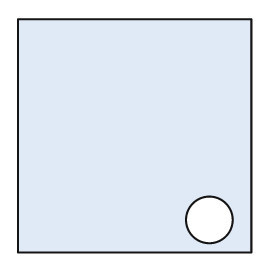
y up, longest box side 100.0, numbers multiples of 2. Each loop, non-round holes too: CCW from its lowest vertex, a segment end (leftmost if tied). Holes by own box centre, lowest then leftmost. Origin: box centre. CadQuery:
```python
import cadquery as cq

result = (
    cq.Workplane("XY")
    .moveTo(-50.0, -50.0)
    .lineTo(50.0, -50.0)
    .lineTo(50.0, 50.0)
    .lineTo(-50.0, 50.0)
    .close()
    .moveTo(32.0, -36.0)
    .circle(10.0)
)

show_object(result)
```